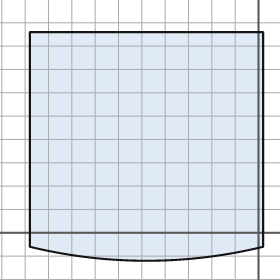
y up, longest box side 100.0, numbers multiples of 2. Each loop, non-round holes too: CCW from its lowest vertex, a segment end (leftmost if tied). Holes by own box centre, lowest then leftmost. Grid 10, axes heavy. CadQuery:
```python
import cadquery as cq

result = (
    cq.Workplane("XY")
    .moveTo(-98.0, -6.0)
    .threePointArc((-48.0, -12.0), (2.0, -6.0))
    .lineTo(2.0, 86.0)
    .lineTo(-98.0, 86.0)
    .close()
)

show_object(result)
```